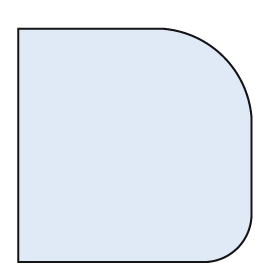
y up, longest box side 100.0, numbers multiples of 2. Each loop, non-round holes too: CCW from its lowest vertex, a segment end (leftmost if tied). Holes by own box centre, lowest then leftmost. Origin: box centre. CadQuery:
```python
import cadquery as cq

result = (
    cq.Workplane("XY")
    .moveTo(-50.0, -50.0)
    .lineTo(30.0, -50.0)
    .threePointArc((44.0, -44.0), (50.0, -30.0))
    .lineTo(50.0, 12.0)
    .threePointArc((38.0, 38.0), (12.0, 50.0))
    .lineTo(-50.0, 50.0)
    .close()
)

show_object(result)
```